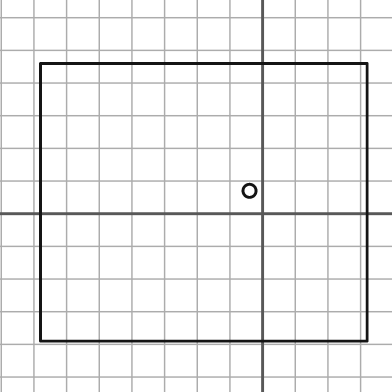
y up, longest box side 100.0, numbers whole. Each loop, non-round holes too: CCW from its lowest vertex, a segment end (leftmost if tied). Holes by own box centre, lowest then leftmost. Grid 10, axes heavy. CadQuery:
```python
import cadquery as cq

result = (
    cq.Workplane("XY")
    .moveTo(-68.0, -39.0)
    .lineTo(32.0, -39.0)
    .lineTo(32.0, 46.0)
    .lineTo(-68.0, 46.0)
    .close()
    .moveTo(-4.0, 7.0)
    .circle(2.0)
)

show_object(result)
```